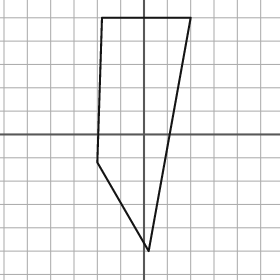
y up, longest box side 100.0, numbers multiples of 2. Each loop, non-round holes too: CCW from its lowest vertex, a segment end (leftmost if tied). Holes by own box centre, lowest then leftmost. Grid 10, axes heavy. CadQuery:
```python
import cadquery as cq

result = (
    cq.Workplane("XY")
    .moveTo(2.0, -50.0)
    .lineTo(20.0, 50.0)
    .lineTo(-18.0, 50.0)
    .lineTo(-20.0, -12.0)
    .close()
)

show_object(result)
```